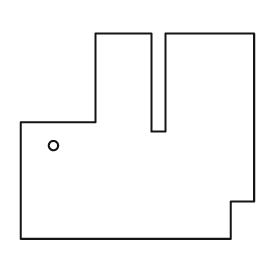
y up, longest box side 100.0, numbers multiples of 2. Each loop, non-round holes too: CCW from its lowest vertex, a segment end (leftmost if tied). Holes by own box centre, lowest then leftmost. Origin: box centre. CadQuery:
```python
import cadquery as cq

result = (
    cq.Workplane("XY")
    .moveTo(-50.0, -44.0)
    .lineTo(40.0, -44.0)
    .lineTo(40.0, -28.0)
    .lineTo(50.0, -28.0)
    .lineTo(50.0, 44.0)
    .lineTo(12.0, 44.0)
    .lineTo(12.0, 2.0)
    .lineTo(6.0, 2.0)
    .lineTo(6.0, 44.0)
    .lineTo(-18.0, 44.0)
    .lineTo(-18.0, 6.0)
    .lineTo(-50.0, 6.0)
    .close()
    .moveTo(-36.0, -4.0)
    .circle(2.0)
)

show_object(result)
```